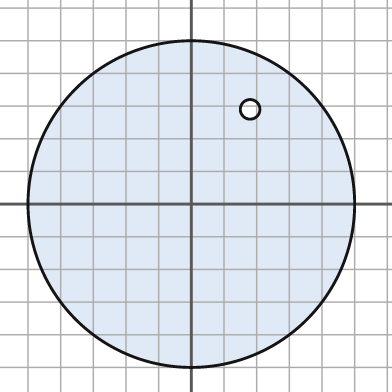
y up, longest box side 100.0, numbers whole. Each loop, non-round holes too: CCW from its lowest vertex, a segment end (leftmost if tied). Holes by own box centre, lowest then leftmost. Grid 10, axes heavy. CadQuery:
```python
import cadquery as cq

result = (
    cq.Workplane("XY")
    .moveTo(0.0, 0.0)
    .circle(50.0)
    .moveTo(18.0, 29.0)
    .circle(3.0)
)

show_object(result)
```